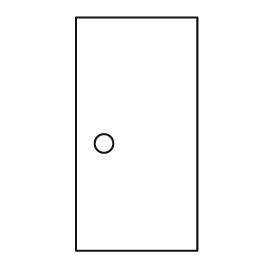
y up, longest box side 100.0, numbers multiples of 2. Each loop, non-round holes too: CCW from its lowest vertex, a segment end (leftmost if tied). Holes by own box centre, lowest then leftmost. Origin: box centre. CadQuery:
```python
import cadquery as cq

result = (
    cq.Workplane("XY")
    .moveTo(-26.0, -50.0)
    .lineTo(26.0, -50.0)
    .lineTo(26.0, 50.0)
    .lineTo(-26.0, 50.0)
    .close()
    .moveTo(-14.0, -4.0)
    .circle(4.0)
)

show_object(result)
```